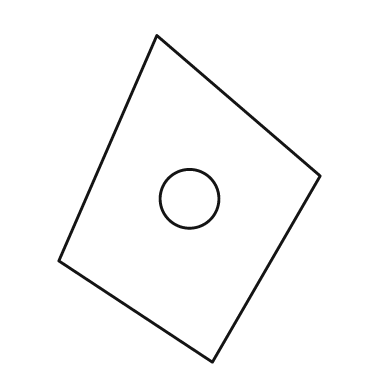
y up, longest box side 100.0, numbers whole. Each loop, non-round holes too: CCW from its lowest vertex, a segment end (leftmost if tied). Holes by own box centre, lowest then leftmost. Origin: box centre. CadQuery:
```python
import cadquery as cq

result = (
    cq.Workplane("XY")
    .moveTo(7.0, -50.0)
    .lineTo(40.0, 7.0)
    .lineTo(-10.0, 50.0)
    .lineTo(-40.0, -19.0)
    .close()
    .moveTo(0.0, 0.0)
    .circle(9.0)
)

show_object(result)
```